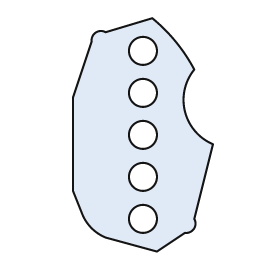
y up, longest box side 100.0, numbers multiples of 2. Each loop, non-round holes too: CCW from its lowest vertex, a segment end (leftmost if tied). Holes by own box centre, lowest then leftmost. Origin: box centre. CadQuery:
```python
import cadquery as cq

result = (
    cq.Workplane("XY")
    .moveTo(6.0, -50.0)
    .lineTo(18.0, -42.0)
    .threePointArc((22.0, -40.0), (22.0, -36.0))
    .lineTo(30.0, -4.0)
    .threePointArc((18.0, 10.0), (22.0, 28.0))
    .threePointArc((14.0, 40.0), (4.0, 50.0))
    .lineTo(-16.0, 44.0)
    .threePointArc((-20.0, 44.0), (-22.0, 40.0))
    .lineTo(-30.0, 16.0)
    .lineTo(-30.0, -24.0)
    .lineTo(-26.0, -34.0)
    .threePointArc((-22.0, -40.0), (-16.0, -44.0))
    .close()
    .moveTo(0.0, -36.0)
    .circle(6.0)
    .moveTo(0.0, -18.0)
    .circle(6.0)
    .moveTo(0.0, 0.0)
    .circle(6.0)
    .moveTo(0.0, 18.0)
    .circle(6.0)
    .moveTo(0.0, 36.0)
    .circle(6.0)
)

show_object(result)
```